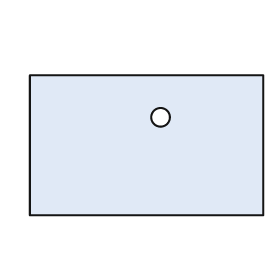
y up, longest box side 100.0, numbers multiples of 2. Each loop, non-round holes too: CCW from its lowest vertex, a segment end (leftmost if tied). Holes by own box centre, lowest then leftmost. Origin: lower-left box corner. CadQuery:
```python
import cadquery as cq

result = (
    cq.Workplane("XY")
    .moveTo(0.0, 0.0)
    .lineTo(100.0, 0.0)
    .lineTo(100.0, 60.0)
    .lineTo(0.0, 60.0)
    .close()
    .moveTo(56.0, 42.0)
    .circle(4.0)
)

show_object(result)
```